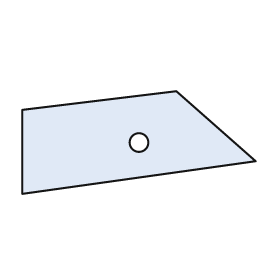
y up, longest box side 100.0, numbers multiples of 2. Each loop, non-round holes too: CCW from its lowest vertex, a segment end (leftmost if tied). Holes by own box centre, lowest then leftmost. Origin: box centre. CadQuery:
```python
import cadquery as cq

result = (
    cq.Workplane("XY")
    .moveTo(-50.0, -22.0)
    .lineTo(50.0, -8.0)
    .lineTo(16.0, 22.0)
    .lineTo(-50.0, 14.0)
    .close()
    .moveTo(0.0, 0.0)
    .circle(4.0)
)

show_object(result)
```